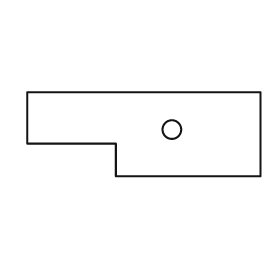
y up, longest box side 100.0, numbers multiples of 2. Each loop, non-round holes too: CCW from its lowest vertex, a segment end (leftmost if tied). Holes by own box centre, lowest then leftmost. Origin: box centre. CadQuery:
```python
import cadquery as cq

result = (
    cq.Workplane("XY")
    .moveTo(-12.0, -18.0)
    .lineTo(50.0, -18.0)
    .lineTo(50.0, 18.0)
    .lineTo(-50.0, 18.0)
    .lineTo(-50.0, -4.0)
    .lineTo(-12.0, -4.0)
    .close()
    .moveTo(12.0, 2.0)
    .circle(4.0)
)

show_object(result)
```